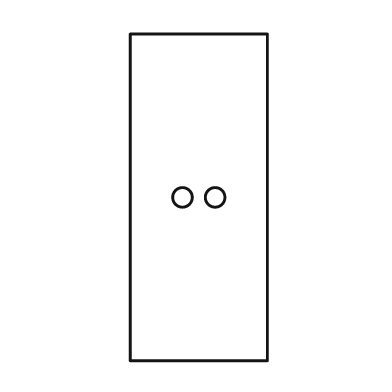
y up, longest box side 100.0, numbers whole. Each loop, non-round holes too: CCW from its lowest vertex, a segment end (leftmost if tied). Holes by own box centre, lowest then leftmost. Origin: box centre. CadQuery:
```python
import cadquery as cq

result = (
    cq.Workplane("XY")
    .moveTo(-21.0, -50.0)
    .lineTo(21.0, -50.0)
    .lineTo(21.0, 50.0)
    .lineTo(-21.0, 50.0)
    .close()
    .moveTo(-5.0, 0.0)
    .circle(3.0)
    .moveTo(5.0, 0.0)
    .circle(3.0)
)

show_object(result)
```